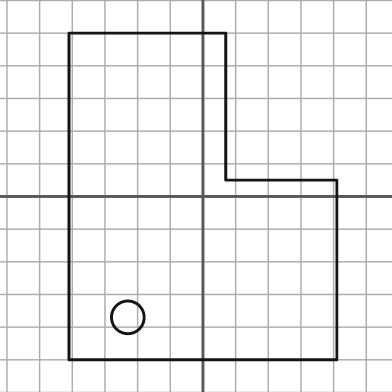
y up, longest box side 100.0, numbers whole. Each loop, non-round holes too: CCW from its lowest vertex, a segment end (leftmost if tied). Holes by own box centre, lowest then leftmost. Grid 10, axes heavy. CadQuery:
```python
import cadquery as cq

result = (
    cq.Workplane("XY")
    .moveTo(-41.0, -50.0)
    .lineTo(41.0, -50.0)
    .lineTo(41.0, 5.0)
    .lineTo(7.0, 5.0)
    .lineTo(7.0, 50.0)
    .lineTo(-41.0, 50.0)
    .close()
    .moveTo(-23.0, -37.0)
    .circle(5.0)
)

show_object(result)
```